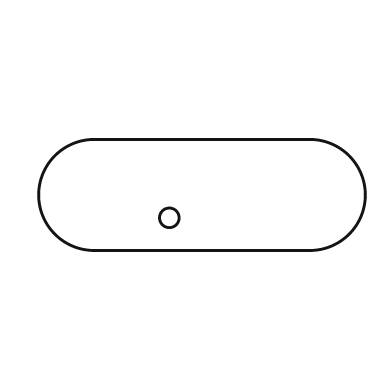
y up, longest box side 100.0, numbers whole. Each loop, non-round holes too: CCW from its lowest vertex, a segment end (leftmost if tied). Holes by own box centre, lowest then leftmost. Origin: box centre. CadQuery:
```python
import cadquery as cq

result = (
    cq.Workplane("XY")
    .moveTo(-33.0, -17.0)
    .lineTo(33.0, -17.0)
    .threePointArc((50.0, 0.0), (33.0, 17.0))
    .lineTo(-33.0, 17.0)
    .threePointArc((-50.0, 0.0), (-33.0, -17.0))
    .close()
    .moveTo(-10.0, -7.0)
    .circle(3.0)
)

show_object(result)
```